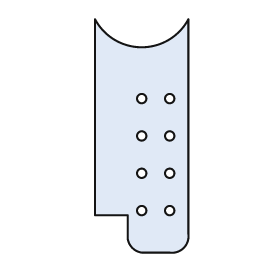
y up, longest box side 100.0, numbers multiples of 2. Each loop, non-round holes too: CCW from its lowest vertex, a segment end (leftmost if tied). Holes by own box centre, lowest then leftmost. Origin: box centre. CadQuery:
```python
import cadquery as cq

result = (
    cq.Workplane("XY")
    .moveTo(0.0, -50.0)
    .lineTo(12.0, -50.0)
    .threePointArc((18.0, -48.0), (20.0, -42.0))
    .lineTo(20.0, 50.0)
    .threePointArc((0.0, 38.0), (-20.0, 50.0))
    .lineTo(-20.0, -34.0)
    .lineTo(-6.0, -34.0)
    .lineTo(-6.0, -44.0)
    .threePointArc((-4.0, -48.0), (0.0, -50.0))
    .close()
    .moveTo(0.0, -32.0)
    .circle(2.0)
    .moveTo(12.0, -32.0)
    .circle(2.0)
    .moveTo(0.0, -16.0)
    .circle(2.0)
    .moveTo(12.0, -16.0)
    .circle(2.0)
    .moveTo(0.0, 0.0)
    .circle(2.0)
    .moveTo(12.0, 0.0)
    .circle(2.0)
    .moveTo(0.0, 16.0)
    .circle(2.0)
    .moveTo(12.0, 16.0)
    .circle(2.0)
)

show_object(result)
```